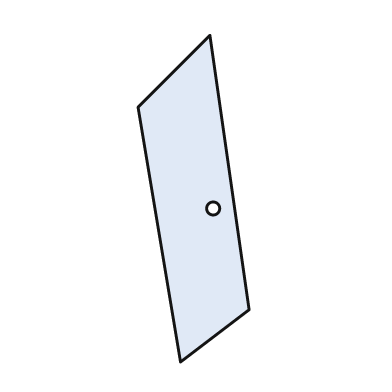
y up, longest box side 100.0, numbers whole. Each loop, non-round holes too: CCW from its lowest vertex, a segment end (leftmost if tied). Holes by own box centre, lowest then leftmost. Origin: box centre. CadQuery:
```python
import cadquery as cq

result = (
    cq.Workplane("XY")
    .moveTo(-4.0, -50.0)
    .lineTo(17.0, -34.0)
    .lineTo(5.0, 50.0)
    .lineTo(-17.0, 28.0)
    .close()
    .moveTo(6.0, -3.0)
    .circle(2.0)
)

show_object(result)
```